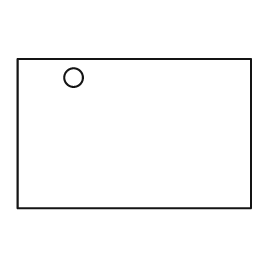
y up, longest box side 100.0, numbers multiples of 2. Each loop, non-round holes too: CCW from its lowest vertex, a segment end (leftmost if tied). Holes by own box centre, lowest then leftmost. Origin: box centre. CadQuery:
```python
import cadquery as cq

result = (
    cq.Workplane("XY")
    .moveTo(-50.0, -32.0)
    .lineTo(50.0, -32.0)
    .lineTo(50.0, 32.0)
    .lineTo(-50.0, 32.0)
    .close()
    .moveTo(-26.0, 24.0)
    .circle(4.0)
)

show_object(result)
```